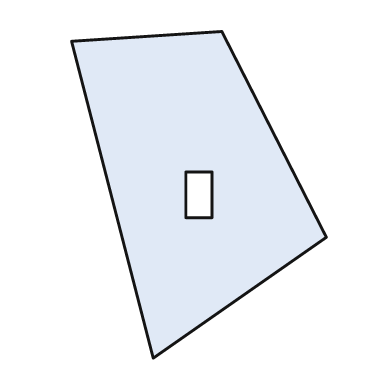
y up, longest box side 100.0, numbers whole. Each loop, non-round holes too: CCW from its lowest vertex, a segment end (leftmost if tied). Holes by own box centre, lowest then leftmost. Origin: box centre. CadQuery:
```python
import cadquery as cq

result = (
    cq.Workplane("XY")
    .moveTo(-14.0, -50.0)
    .lineTo(39.0, -13.0)
    .lineTo(7.0, 50.0)
    .lineTo(-39.0, 47.0)
    .close()
    .moveTo(-4.0, -7.0)
    .lineTo(4.0, -7.0)
    .lineTo(4.0, 7.0)
    .lineTo(-4.0, 7.0)
    .close()
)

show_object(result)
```